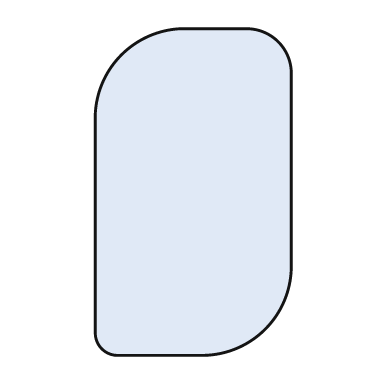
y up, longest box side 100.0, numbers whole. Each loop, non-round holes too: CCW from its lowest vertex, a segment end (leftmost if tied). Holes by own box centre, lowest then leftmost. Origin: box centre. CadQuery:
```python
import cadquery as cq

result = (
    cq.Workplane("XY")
    .moveTo(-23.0, -50.0)
    .lineTo(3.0, -50.0)
    .threePointArc((22.0, -42.0), (30.0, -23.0))
    .lineTo(30.0, 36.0)
    .threePointArc((26.0, 46.0), (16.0, 50.0))
    .lineTo(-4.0, 50.0)
    .threePointArc((-22.0, 42.0), (-30.0, 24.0))
    .lineTo(-30.0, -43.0)
    .threePointArc((-28.0, -48.0), (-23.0, -50.0))
    .close()
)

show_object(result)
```